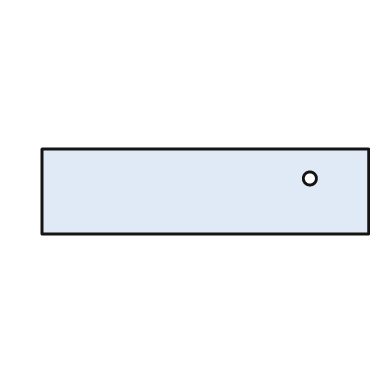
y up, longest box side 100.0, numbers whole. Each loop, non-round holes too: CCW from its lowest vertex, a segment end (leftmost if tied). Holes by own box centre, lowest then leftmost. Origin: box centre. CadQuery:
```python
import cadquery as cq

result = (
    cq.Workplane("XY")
    .moveTo(-50.0, -13.0)
    .lineTo(50.0, -13.0)
    .lineTo(50.0, 13.0)
    .lineTo(-50.0, 13.0)
    .close()
    .moveTo(32.0, 4.0)
    .circle(2.0)
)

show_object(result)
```